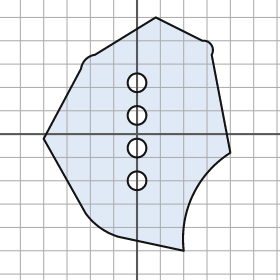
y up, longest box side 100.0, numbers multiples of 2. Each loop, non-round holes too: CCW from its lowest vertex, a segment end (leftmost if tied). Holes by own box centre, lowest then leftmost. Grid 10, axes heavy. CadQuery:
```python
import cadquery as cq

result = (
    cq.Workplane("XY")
    .moveTo(20.0, -50.0)
    .threePointArc((24.0, -26.0), (40.0, -8.0))
    .lineTo(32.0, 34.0)
    .threePointArc((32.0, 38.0), (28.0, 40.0))
    .lineTo(8.0, 50.0)
    .lineTo(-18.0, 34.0)
    .threePointArc((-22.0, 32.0), (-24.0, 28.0))
    .lineTo(-40.0, -2.0)
    .lineTo(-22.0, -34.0)
    .threePointArc((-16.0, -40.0), (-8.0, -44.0))
    .close()
    .moveTo(0.0, -20.0)
    .circle(4.0)
    .moveTo(0.0, -6.0)
    .circle(4.0)
    .moveTo(0.0, 8.0)
    .circle(4.0)
    .moveTo(0.0, 22.0)
    .circle(4.0)
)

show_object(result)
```